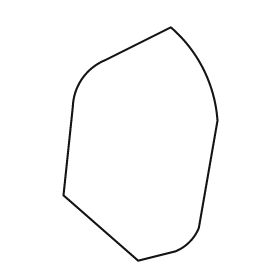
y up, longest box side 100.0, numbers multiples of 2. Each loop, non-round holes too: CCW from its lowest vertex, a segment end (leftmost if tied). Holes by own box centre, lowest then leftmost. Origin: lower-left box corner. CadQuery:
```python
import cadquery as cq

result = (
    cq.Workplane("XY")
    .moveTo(32.0, 0.0)
    .lineTo(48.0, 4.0)
    .threePointArc((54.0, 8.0), (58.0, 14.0))
    .lineTo(66.0, 60.0)
    .threePointArc((60.0, 82.0), (46.0, 100.0))
    .lineTo(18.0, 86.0)
    .threePointArc((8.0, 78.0), (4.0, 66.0))
    .lineTo(0.0, 28.0)
    .close()
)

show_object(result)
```